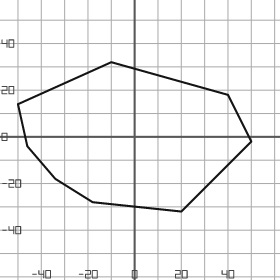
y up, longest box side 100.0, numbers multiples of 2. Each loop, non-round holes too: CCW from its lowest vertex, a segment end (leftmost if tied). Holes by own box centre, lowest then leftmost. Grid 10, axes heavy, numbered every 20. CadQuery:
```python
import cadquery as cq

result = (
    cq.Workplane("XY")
    .moveTo(20.0, -32.0)
    .lineTo(50.0, -2.0)
    .lineTo(40.0, 18.0)
    .lineTo(-10.0, 32.0)
    .lineTo(-50.0, 14.0)
    .lineTo(-46.0, -4.0)
    .lineTo(-34.0, -18.0)
    .lineTo(-18.0, -28.0)
    .close()
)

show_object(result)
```